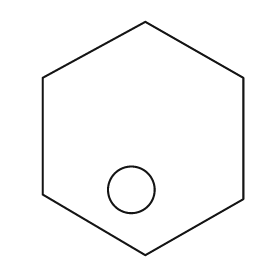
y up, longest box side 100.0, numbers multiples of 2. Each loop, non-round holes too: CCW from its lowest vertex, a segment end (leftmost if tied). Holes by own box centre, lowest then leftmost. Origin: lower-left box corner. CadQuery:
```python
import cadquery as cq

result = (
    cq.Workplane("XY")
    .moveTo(44.0, 0.0)
    .lineTo(86.0, 24.0)
    .lineTo(86.0, 76.0)
    .lineTo(44.0, 100.0)
    .lineTo(0.0, 76.0)
    .lineTo(0.0, 26.0)
    .close()
    .moveTo(38.0, 28.0)
    .circle(10.0)
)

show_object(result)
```